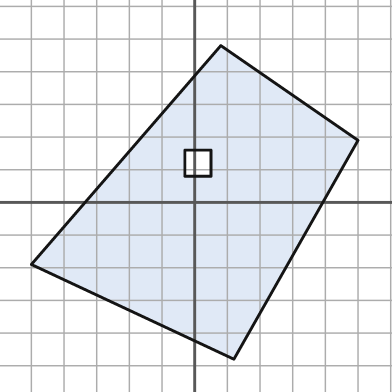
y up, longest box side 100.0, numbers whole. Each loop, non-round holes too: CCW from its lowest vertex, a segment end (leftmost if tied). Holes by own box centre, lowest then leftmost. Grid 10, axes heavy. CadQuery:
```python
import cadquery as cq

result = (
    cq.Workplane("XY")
    .moveTo(12.0, -48.0)
    .lineTo(50.0, 19.0)
    .lineTo(8.0, 48.0)
    .lineTo(-50.0, -19.0)
    .close()
    .moveTo(-3.0, 8.0)
    .lineTo(5.0, 8.0)
    .lineTo(5.0, 16.0)
    .lineTo(-3.0, 16.0)
    .close()
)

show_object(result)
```